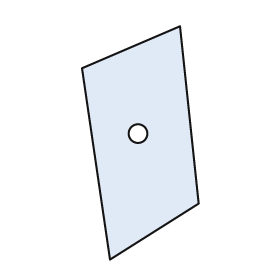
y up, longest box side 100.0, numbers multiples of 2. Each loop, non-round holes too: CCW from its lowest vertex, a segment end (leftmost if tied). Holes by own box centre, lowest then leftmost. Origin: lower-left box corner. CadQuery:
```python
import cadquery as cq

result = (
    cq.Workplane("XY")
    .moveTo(12.0, 0.0)
    .lineTo(50.0, 24.0)
    .lineTo(42.0, 100.0)
    .lineTo(0.0, 82.0)
    .close()
    .moveTo(24.0, 54.0)
    .circle(4.0)
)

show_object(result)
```